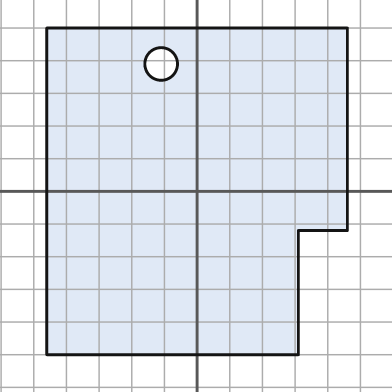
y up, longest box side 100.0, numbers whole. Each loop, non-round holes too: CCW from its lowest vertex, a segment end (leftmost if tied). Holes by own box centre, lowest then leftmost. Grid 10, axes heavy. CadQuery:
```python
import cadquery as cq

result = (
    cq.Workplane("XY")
    .moveTo(-46.0, -50.0)
    .lineTo(31.0, -50.0)
    .lineTo(31.0, -12.0)
    .lineTo(46.0, -12.0)
    .lineTo(46.0, 50.0)
    .lineTo(-46.0, 50.0)
    .close()
    .moveTo(-11.0, 39.0)
    .circle(5.0)
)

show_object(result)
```